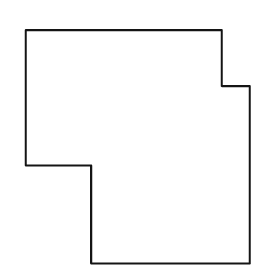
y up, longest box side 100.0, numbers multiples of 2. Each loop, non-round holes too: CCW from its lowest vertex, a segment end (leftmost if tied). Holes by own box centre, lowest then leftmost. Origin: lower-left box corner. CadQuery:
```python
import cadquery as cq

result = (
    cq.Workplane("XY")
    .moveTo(28.0, 0.0)
    .lineTo(96.0, 0.0)
    .lineTo(96.0, 76.0)
    .lineTo(84.0, 76.0)
    .lineTo(84.0, 100.0)
    .lineTo(0.0, 100.0)
    .lineTo(0.0, 42.0)
    .lineTo(28.0, 42.0)
    .close()
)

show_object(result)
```